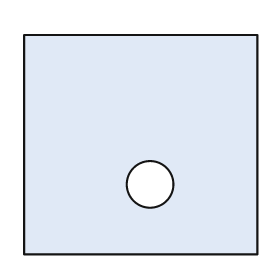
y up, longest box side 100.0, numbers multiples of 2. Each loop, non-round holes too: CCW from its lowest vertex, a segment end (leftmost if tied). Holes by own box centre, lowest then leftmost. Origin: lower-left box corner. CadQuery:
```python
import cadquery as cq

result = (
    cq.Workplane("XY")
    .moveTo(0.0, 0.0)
    .lineTo(100.0, 0.0)
    .lineTo(100.0, 94.0)
    .lineTo(0.0, 94.0)
    .close()
    .moveTo(54.0, 30.0)
    .circle(10.0)
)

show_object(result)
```